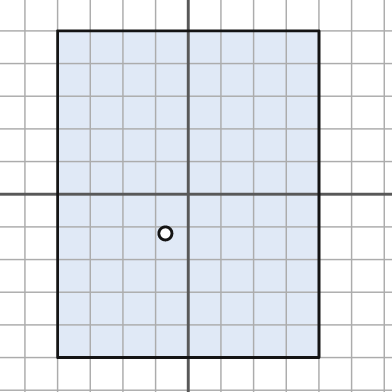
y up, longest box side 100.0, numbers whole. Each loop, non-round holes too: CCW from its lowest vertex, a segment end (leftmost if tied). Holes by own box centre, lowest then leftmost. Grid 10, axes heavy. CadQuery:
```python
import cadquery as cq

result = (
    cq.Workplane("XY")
    .moveTo(-40.0, -50.0)
    .lineTo(40.0, -50.0)
    .lineTo(40.0, 50.0)
    .lineTo(-40.0, 50.0)
    .close()
    .moveTo(-7.0, -12.0)
    .circle(2.0)
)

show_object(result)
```